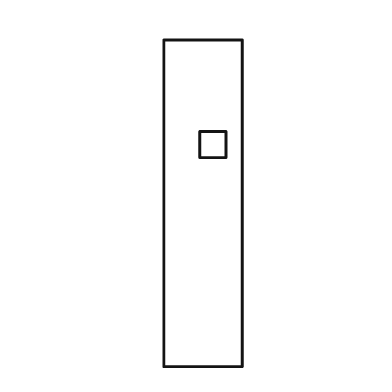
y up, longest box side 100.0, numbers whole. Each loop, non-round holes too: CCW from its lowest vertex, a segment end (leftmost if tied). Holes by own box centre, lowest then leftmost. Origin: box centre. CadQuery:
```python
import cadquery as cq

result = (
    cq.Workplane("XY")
    .moveTo(-12.0, -50.0)
    .lineTo(12.0, -50.0)
    .lineTo(12.0, 50.0)
    .lineTo(-12.0, 50.0)
    .close()
    .moveTo(-1.0, 14.0)
    .lineTo(7.0, 14.0)
    .lineTo(7.0, 22.0)
    .lineTo(-1.0, 22.0)
    .close()
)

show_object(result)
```